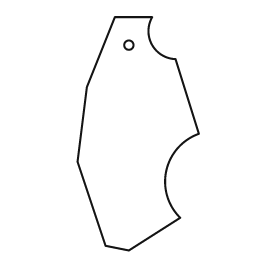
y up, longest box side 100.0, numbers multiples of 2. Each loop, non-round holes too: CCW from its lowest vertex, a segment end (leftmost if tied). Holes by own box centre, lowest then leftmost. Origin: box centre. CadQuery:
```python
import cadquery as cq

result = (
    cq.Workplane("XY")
    .moveTo(-4.0, -50.0)
    .lineTo(18.0, -36.0)
    .threePointArc((12.0, -16.0), (26.0, 0.0))
    .lineTo(16.0, 32.0)
    .threePointArc((6.0, 38.0), (6.0, 50.0))
    .lineTo(-10.0, 50.0)
    .lineTo(-22.0, 20.0)
    .lineTo(-26.0, -12.0)
    .lineTo(-14.0, -48.0)
    .close()
    .moveTo(-4.0, 38.0)
    .circle(2.0)
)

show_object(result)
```